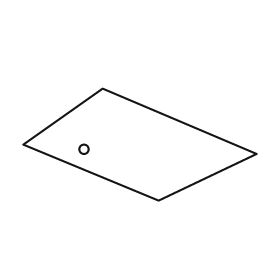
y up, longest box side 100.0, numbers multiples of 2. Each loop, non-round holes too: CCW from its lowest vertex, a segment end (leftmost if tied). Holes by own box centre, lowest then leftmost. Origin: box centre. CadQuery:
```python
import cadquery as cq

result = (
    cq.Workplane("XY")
    .moveTo(8.0, -24.0)
    .lineTo(50.0, -4.0)
    .lineTo(-16.0, 24.0)
    .lineTo(-50.0, 0.0)
    .close()
    .moveTo(-24.0, -2.0)
    .circle(2.0)
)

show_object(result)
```